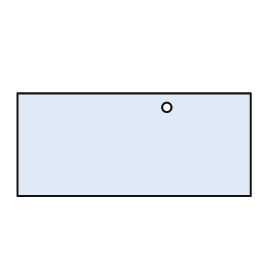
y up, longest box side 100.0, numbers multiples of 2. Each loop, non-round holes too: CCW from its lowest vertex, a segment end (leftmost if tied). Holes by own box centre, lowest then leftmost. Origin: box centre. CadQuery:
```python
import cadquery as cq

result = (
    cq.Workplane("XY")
    .moveTo(-50.0, -22.0)
    .lineTo(50.0, -22.0)
    .lineTo(50.0, 22.0)
    .lineTo(-50.0, 22.0)
    .close()
    .moveTo(14.0, 16.0)
    .circle(2.0)
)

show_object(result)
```